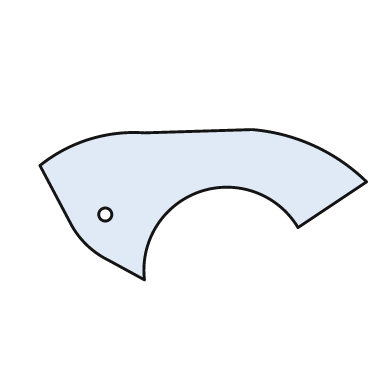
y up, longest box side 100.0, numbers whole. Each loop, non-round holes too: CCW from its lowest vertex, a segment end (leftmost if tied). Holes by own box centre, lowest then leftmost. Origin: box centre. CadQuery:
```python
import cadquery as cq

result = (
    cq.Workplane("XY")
    .moveTo(-18.0, -23.0)
    .threePointArc((-1.0, 4.0), (29.0, -7.0))
    .lineTo(50.0, 7.0)
    .threePointArc((34.0, 18.0), (15.0, 23.0))
    .lineTo(-18.0, 22.0)
    .threePointArc((-35.0, 20.0), (-50.0, 12.0))
    .lineTo(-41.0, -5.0)
    .threePointArc((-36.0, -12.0), (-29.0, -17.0))
    .close()
    .moveTo(-30.0, -3.0)
    .circle(2.0)
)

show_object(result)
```